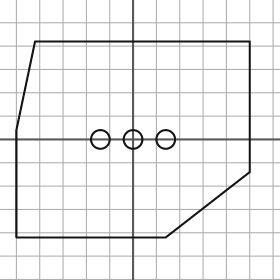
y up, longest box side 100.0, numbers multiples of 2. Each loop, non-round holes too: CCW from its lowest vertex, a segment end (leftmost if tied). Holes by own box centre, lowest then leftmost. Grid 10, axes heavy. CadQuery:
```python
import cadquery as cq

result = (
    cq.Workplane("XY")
    .moveTo(-50.0, -42.0)
    .lineTo(14.0, -42.0)
    .lineTo(50.0, -14.0)
    .lineTo(50.0, 42.0)
    .lineTo(-42.0, 42.0)
    .lineTo(-50.0, 4.0)
    .close()
    .moveTo(-14.0, 0.0)
    .circle(4.0)
    .moveTo(0.0, 0.0)
    .circle(4.0)
    .moveTo(14.0, 0.0)
    .circle(4.0)
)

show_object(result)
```